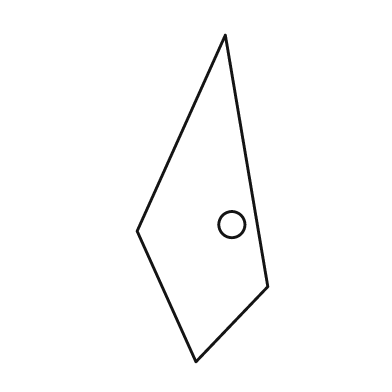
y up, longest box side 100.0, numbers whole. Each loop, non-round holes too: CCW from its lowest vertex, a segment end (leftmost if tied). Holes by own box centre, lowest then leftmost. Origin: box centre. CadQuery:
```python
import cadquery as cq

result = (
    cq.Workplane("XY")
    .moveTo(-2.0, -50.0)
    .lineTo(20.0, -27.0)
    .lineTo(7.0, 50.0)
    .lineTo(-20.0, -10.0)
    .close()
    .moveTo(9.0, -8.0)
    .circle(4.0)
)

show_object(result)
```